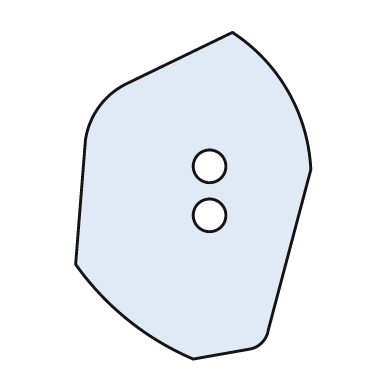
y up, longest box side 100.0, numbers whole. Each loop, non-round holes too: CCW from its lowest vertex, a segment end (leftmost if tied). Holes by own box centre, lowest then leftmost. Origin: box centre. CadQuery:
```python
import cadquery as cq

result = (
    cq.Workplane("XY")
    .moveTo(0.0, -50.0)
    .lineTo(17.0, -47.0)
    .threePointArc((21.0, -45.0), (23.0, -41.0))
    .lineTo(36.0, 8.0)
    .threePointArc((29.0, 32.0), (12.0, 50.0))
    .lineTo(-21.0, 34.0)
    .threePointArc((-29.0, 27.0), (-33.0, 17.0))
    .lineTo(-36.0, -21.0)
    .threePointArc((-20.0, -38.0), (0.0, -50.0))
    .close()
    .moveTo(5.0, -6.0)
    .circle(5.0)
    .moveTo(5.0, 9.0)
    .circle(5.0)
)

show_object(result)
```